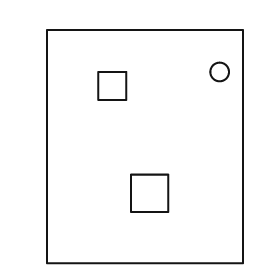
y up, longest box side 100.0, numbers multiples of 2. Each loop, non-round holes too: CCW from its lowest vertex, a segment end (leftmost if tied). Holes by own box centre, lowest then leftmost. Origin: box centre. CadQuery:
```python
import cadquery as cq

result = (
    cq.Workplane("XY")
    .moveTo(-42.0, -50.0)
    .lineTo(42.0, -50.0)
    .lineTo(42.0, 50.0)
    .lineTo(-42.0, 50.0)
    .close()
    .moveTo(-6.0, -28.0)
    .lineTo(10.0, -28.0)
    .lineTo(10.0, -12.0)
    .lineTo(-6.0, -12.0)
    .close()
    .moveTo(-20.0, 20.0)
    .lineTo(-8.0, 20.0)
    .lineTo(-8.0, 32.0)
    .lineTo(-20.0, 32.0)
    .close()
    .moveTo(32.0, 32.0)
    .circle(4.0)
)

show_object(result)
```